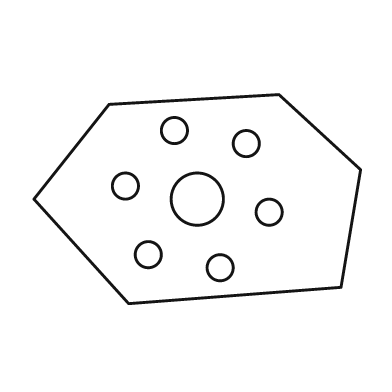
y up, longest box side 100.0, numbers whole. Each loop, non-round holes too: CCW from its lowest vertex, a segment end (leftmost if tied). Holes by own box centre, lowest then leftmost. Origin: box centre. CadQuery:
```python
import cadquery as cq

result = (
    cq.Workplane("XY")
    .moveTo(-21.0, -32.0)
    .lineTo(44.0, -27.0)
    .lineTo(50.0, 9.0)
    .lineTo(25.0, 32.0)
    .lineTo(-27.0, 29.0)
    .lineTo(-50.0, 0.0)
    .close()
    .moveTo(7.0, -21.0)
    .circle(4.0)
    .moveTo(-15.0, -17.0)
    .circle(4.0)
    .moveTo(22.0, -4.0)
    .circle(4.0)
    .moveTo(0.0, 0.0)
    .circle(8.0)
    .moveTo(-22.0, 4.0)
    .circle(4.0)
    .moveTo(15.0, 17.0)
    .circle(4.0)
    .moveTo(-7.0, 21.0)
    .circle(4.0)
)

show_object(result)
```